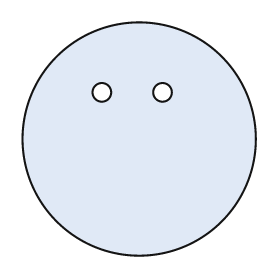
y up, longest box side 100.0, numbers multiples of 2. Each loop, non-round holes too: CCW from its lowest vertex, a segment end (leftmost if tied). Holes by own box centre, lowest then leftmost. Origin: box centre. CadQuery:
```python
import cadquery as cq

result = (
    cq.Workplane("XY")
    .moveTo(0.0, 0.0)
    .circle(50.0)
    .moveTo(-16.0, 20.0)
    .circle(4.0)
    .moveTo(10.0, 20.0)
    .circle(4.0)
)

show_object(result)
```